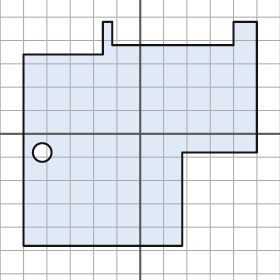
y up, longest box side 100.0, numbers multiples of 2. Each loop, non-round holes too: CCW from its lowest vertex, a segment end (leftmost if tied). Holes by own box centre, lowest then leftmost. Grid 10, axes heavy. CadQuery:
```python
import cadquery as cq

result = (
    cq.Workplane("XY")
    .moveTo(-50.0, -48.0)
    .lineTo(18.0, -48.0)
    .lineTo(18.0, -8.0)
    .lineTo(50.0, -8.0)
    .lineTo(50.0, 48.0)
    .lineTo(40.0, 48.0)
    .lineTo(40.0, 38.0)
    .lineTo(-12.0, 38.0)
    .lineTo(-12.0, 48.0)
    .lineTo(-16.0, 48.0)
    .lineTo(-16.0, 34.0)
    .lineTo(-50.0, 34.0)
    .close()
    .moveTo(-42.0, -8.0)
    .circle(4.0)
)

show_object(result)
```